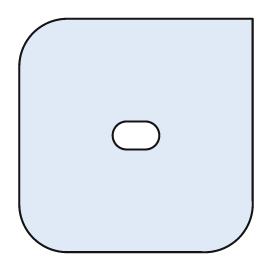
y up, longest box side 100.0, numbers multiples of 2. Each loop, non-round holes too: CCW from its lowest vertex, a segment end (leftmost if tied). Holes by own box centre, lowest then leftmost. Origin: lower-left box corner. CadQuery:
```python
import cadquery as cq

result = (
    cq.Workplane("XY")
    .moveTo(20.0, 0.0)
    .lineTo(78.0, 0.0)
    .threePointArc((94.0, 6.0), (100.0, 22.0))
    .lineTo(100.0, 100.0)
    .lineTo(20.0, 100.0)
    .threePointArc((6.0, 94.0), (0.0, 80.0))
    .lineTo(0.0, 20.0)
    .threePointArc((6.0, 6.0), (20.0, 0.0))
    .close()
    .moveTo(46.0, 44.0)
    .lineTo(54.0, 44.0)
    .threePointArc((60.0, 50.0), (54.0, 56.0))
    .lineTo(46.0, 56.0)
    .threePointArc((40.0, 50.0), (46.0, 44.0))
    .close()
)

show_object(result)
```